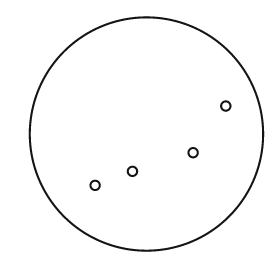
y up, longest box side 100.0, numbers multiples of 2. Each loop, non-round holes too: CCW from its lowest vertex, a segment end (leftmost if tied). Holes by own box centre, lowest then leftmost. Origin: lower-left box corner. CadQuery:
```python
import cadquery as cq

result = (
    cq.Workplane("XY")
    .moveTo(50.0, 50.0)
    .circle(50.0)
    .moveTo(28.0, 28.0)
    .circle(2.0)
    .moveTo(44.0, 34.0)
    .circle(2.0)
    .moveTo(70.0, 42.0)
    .circle(2.0)
    .moveTo(84.0, 62.0)
    .circle(2.0)
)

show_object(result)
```